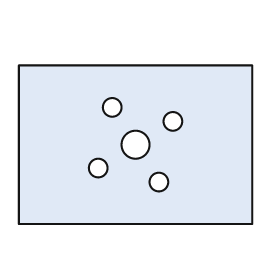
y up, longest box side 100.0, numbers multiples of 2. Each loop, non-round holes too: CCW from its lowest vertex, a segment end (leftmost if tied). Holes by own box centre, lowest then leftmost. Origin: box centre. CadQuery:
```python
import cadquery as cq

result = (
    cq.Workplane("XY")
    .moveTo(-50.0, -34.0)
    .lineTo(50.0, -34.0)
    .lineTo(50.0, 34.0)
    .lineTo(-50.0, 34.0)
    .close()
    .moveTo(10.0, -16.0)
    .circle(4.0)
    .moveTo(-16.0, -10.0)
    .circle(4.0)
    .moveTo(0.0, 0.0)
    .circle(6.0)
    .moveTo(16.0, 10.0)
    .circle(4.0)
    .moveTo(-10.0, 16.0)
    .circle(4.0)
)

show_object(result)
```